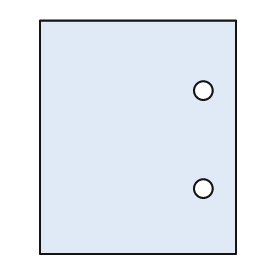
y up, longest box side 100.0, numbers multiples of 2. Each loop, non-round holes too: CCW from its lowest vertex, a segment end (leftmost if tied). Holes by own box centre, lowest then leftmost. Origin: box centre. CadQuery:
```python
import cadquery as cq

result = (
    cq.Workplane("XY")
    .moveTo(-42.0, -50.0)
    .lineTo(42.0, -50.0)
    .lineTo(42.0, 50.0)
    .lineTo(-42.0, 50.0)
    .close()
    .moveTo(28.0, -22.0)
    .circle(4.0)
    .moveTo(28.0, 20.0)
    .circle(4.0)
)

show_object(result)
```